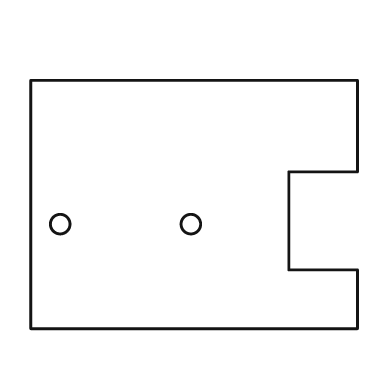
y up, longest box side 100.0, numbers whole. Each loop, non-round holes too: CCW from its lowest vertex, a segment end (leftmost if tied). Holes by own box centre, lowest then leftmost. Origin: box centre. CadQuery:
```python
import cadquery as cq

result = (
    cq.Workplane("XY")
    .moveTo(-50.0, -38.0)
    .lineTo(50.0, -38.0)
    .lineTo(50.0, -20.0)
    .lineTo(29.0, -20.0)
    .lineTo(29.0, 10.0)
    .lineTo(50.0, 10.0)
    .lineTo(50.0, 38.0)
    .lineTo(-50.0, 38.0)
    .close()
    .moveTo(-41.0, -6.0)
    .circle(3.0)
    .moveTo(-1.0, -6.0)
    .circle(3.0)
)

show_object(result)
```